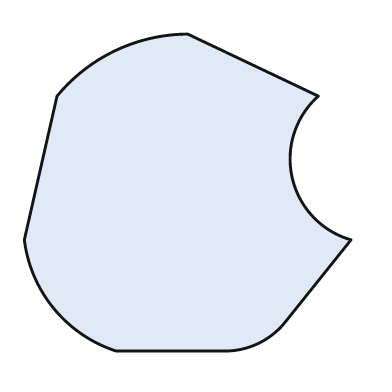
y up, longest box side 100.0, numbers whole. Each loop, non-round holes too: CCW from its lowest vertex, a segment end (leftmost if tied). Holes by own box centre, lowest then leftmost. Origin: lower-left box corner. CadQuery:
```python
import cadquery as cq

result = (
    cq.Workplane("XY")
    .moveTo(28.0, 0.0)
    .lineTo(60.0, 0.0)
    .threePointArc((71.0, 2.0), (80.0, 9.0))
    .lineTo(100.0, 34.0)
    .threePointArc((82.0, 53.0), (90.0, 78.0))
    .lineTo(50.0, 97.0)
    .threePointArc((28.0, 92.0), (10.0, 78.0))
    .lineTo(0.0, 34.0)
    .threePointArc((9.0, 13.0), (28.0, 0.0))
    .close()
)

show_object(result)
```